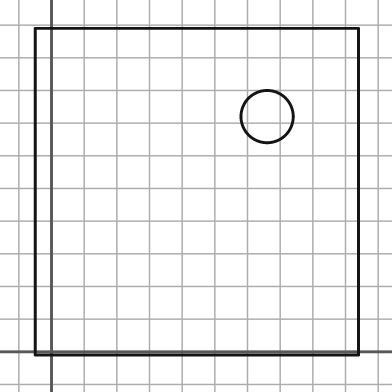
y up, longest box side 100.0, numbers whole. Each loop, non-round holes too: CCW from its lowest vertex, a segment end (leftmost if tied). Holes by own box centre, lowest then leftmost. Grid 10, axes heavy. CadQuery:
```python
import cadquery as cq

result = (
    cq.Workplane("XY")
    .moveTo(-5.0, -1.0)
    .lineTo(94.0, -1.0)
    .lineTo(94.0, 99.0)
    .lineTo(-5.0, 99.0)
    .close()
    .moveTo(66.0, 72.0)
    .circle(8.0)
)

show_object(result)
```